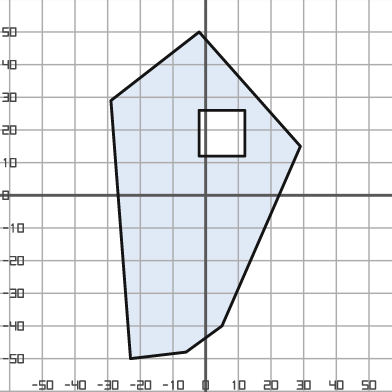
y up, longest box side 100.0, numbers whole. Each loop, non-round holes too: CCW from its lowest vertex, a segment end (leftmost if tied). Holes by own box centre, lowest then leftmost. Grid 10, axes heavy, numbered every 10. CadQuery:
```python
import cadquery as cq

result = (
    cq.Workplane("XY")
    .moveTo(-23.0, -50.0)
    .lineTo(-6.0, -48.0)
    .lineTo(5.0, -40.0)
    .lineTo(29.0, 15.0)
    .lineTo(-2.0, 50.0)
    .lineTo(-29.0, 29.0)
    .close()
    .moveTo(-2.0, 12.0)
    .lineTo(12.0, 12.0)
    .lineTo(12.0, 26.0)
    .lineTo(-2.0, 26.0)
    .close()
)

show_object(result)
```